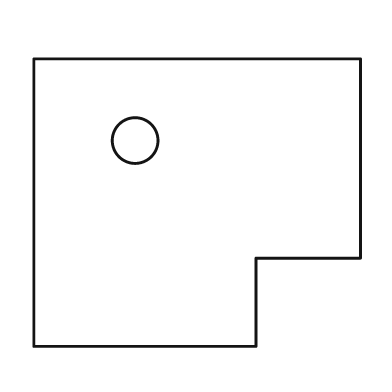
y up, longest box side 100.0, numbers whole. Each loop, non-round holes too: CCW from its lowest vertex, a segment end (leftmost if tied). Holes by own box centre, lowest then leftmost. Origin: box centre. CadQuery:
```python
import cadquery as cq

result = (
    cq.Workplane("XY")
    .moveTo(-50.0, -44.0)
    .lineTo(18.0, -44.0)
    .lineTo(18.0, -17.0)
    .lineTo(50.0, -17.0)
    .lineTo(50.0, 44.0)
    .lineTo(-50.0, 44.0)
    .close()
    .moveTo(-19.0, 19.0)
    .circle(7.0)
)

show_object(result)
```